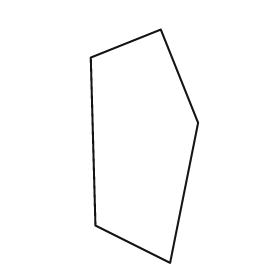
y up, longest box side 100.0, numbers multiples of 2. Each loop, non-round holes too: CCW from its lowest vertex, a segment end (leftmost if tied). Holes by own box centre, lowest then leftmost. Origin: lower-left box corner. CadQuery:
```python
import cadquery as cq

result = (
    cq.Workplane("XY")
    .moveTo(34.0, 0.0)
    .lineTo(46.0, 60.0)
    .lineTo(30.0, 100.0)
    .lineTo(0.0, 88.0)
    .lineTo(2.0, 16.0)
    .close()
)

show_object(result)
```